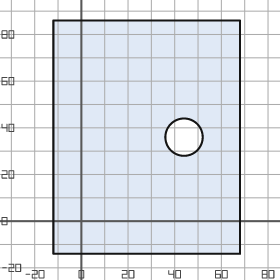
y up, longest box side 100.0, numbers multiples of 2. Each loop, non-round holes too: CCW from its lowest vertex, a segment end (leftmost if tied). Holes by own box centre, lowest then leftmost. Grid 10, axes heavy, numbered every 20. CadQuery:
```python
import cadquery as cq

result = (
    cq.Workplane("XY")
    .moveTo(-12.0, -14.0)
    .lineTo(68.0, -14.0)
    .lineTo(68.0, 86.0)
    .lineTo(-12.0, 86.0)
    .close()
    .moveTo(44.0, 36.0)
    .circle(8.0)
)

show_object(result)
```